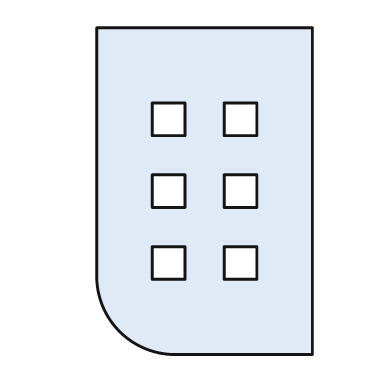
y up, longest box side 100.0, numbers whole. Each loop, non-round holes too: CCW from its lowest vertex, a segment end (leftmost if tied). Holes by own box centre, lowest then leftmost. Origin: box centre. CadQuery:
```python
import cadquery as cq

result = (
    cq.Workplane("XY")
    .moveTo(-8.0, -50.0)
    .lineTo(33.0, -50.0)
    .lineTo(33.0, 50.0)
    .lineTo(-33.0, 50.0)
    .lineTo(-33.0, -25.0)
    .threePointArc((-26.0, -43.0), (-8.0, -50.0))
    .close()
    .moveTo(-16.0, -27.0)
    .lineTo(-6.0, -27.0)
    .lineTo(-6.0, -17.0)
    .lineTo(-16.0, -17.0)
    .close()
    .moveTo(6.0, -27.0)
    .lineTo(16.0, -27.0)
    .lineTo(16.0, -17.0)
    .lineTo(6.0, -17.0)
    .close()
    .moveTo(-16.0, -5.0)
    .lineTo(-6.0, -5.0)
    .lineTo(-6.0, 5.0)
    .lineTo(-16.0, 5.0)
    .close()
    .moveTo(6.0, -5.0)
    .lineTo(16.0, -5.0)
    .lineTo(16.0, 5.0)
    .lineTo(6.0, 5.0)
    .close()
    .moveTo(-16.0, 17.0)
    .lineTo(-6.0, 17.0)
    .lineTo(-6.0, 27.0)
    .lineTo(-16.0, 27.0)
    .close()
    .moveTo(6.0, 17.0)
    .lineTo(16.0, 17.0)
    .lineTo(16.0, 27.0)
    .lineTo(6.0, 27.0)
    .close()
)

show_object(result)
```